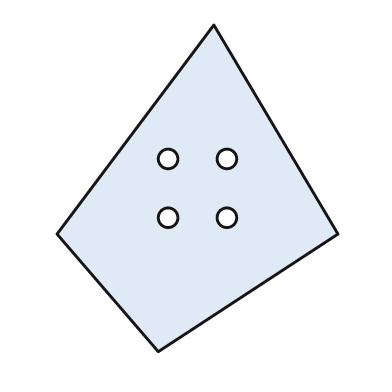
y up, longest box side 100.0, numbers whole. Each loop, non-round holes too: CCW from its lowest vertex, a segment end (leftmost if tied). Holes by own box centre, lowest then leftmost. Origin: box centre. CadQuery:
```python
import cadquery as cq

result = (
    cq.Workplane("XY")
    .moveTo(-12.0, -50.0)
    .lineTo(43.0, -14.0)
    .lineTo(5.0, 50.0)
    .lineTo(-43.0, -14.0)
    .close()
    .moveTo(-9.0, -9.0)
    .circle(3.0)
    .moveTo(9.0, -9.0)
    .circle(3.0)
    .moveTo(-9.0, 9.0)
    .circle(3.0)
    .moveTo(9.0, 9.0)
    .circle(3.0)
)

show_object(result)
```